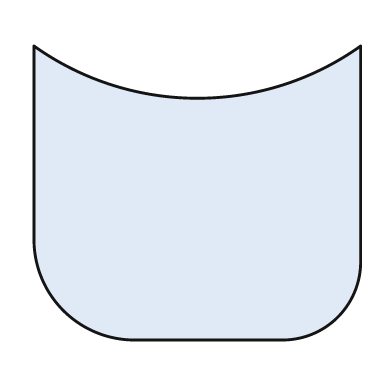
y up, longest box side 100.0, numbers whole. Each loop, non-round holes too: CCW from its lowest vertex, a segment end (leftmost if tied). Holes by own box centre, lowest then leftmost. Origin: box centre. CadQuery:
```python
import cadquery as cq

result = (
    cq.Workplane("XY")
    .moveTo(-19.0, -45.0)
    .lineTo(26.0, -45.0)
    .threePointArc((43.0, -38.0), (50.0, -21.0))
    .lineTo(50.0, 45.0)
    .threePointArc((0.0, 29.0), (-50.0, 45.0))
    .lineTo(-50.0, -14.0)
    .threePointArc((-41.0, -36.0), (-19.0, -45.0))
    .close()
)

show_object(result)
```